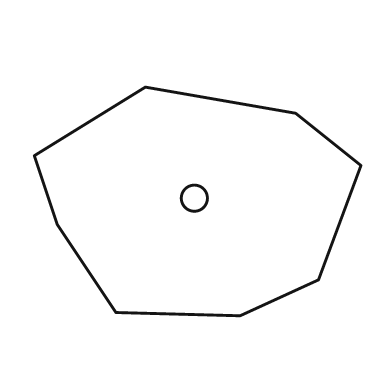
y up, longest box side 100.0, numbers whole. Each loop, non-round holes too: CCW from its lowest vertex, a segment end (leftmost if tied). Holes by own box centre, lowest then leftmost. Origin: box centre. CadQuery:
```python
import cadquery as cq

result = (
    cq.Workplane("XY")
    .moveTo(13.0, -35.0)
    .lineTo(37.0, -24.0)
    .lineTo(50.0, 11.0)
    .lineTo(30.0, 27.0)
    .lineTo(-16.0, 35.0)
    .lineTo(-50.0, 14.0)
    .lineTo(-43.0, -7.0)
    .lineTo(-25.0, -34.0)
    .close()
    .moveTo(-1.0, 1.0)
    .circle(4.0)
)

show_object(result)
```